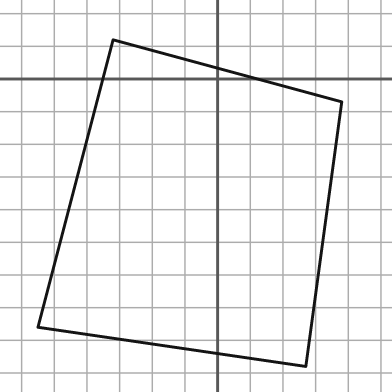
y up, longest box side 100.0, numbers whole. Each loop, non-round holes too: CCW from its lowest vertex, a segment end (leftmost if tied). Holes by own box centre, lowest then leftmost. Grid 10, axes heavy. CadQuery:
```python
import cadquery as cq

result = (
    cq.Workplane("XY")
    .moveTo(27.0, -88.0)
    .lineTo(38.0, -7.0)
    .lineTo(-32.0, 12.0)
    .lineTo(-55.0, -76.0)
    .close()
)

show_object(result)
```